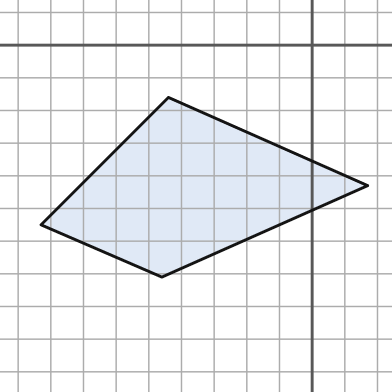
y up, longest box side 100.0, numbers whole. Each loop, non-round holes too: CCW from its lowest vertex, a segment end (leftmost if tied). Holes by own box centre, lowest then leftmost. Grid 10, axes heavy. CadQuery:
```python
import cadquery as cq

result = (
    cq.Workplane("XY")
    .moveTo(-46.0, -71.0)
    .lineTo(17.0, -43.0)
    .lineTo(-44.0, -16.0)
    .lineTo(-83.0, -55.0)
    .close()
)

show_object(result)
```